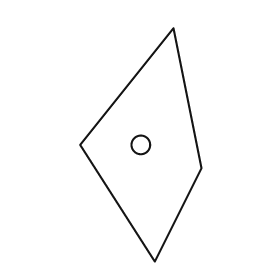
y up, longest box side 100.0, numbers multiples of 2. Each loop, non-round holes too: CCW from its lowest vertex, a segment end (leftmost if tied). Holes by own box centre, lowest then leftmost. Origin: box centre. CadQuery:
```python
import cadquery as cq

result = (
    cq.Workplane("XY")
    .moveTo(6.0, -50.0)
    .lineTo(26.0, -10.0)
    .lineTo(14.0, 50.0)
    .lineTo(-26.0, 0.0)
    .close()
    .moveTo(0.0, 0.0)
    .circle(4.0)
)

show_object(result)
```